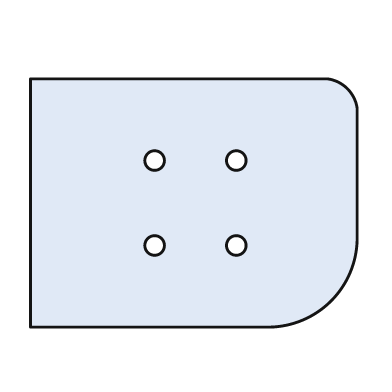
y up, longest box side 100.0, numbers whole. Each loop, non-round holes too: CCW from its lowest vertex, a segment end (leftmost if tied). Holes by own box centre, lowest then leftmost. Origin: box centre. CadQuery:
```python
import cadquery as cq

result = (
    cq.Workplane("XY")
    .moveTo(-50.0, -38.0)
    .lineTo(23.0, -38.0)
    .threePointArc((42.0, -30.0), (50.0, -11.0))
    .lineTo(50.0, 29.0)
    .threePointArc((47.0, 35.0), (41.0, 38.0))
    .lineTo(-50.0, 38.0)
    .close()
    .moveTo(-12.0, -13.0)
    .circle(3.0)
    .moveTo(13.0, -13.0)
    .circle(3.0)
    .moveTo(-12.0, 13.0)
    .circle(3.0)
    .moveTo(13.0, 13.0)
    .circle(3.0)
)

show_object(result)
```